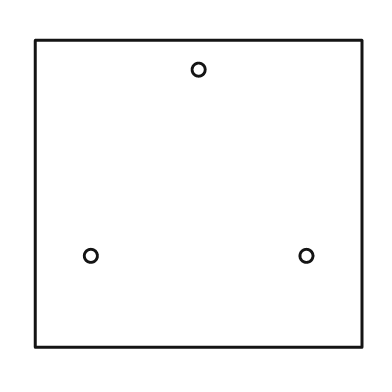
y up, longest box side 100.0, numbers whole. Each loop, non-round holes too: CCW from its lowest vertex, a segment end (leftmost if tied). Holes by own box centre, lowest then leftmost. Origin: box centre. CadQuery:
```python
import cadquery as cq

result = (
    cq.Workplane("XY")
    .moveTo(-50.0, -47.0)
    .lineTo(50.0, -47.0)
    .lineTo(50.0, 47.0)
    .lineTo(-50.0, 47.0)
    .close()
    .moveTo(-33.0, -19.0)
    .circle(2.0)
    .moveTo(33.0, -19.0)
    .circle(2.0)
    .moveTo(0.0, 38.0)
    .circle(2.0)
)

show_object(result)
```